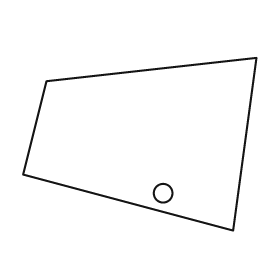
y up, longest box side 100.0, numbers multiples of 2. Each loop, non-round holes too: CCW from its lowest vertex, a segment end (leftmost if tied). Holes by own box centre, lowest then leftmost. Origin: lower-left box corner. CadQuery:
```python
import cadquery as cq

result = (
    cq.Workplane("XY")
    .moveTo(90.0, 0.0)
    .lineTo(100.0, 74.0)
    .lineTo(10.0, 64.0)
    .lineTo(0.0, 24.0)
    .close()
    .moveTo(60.0, 16.0)
    .circle(4.0)
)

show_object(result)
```